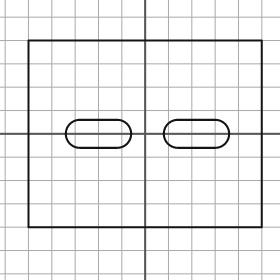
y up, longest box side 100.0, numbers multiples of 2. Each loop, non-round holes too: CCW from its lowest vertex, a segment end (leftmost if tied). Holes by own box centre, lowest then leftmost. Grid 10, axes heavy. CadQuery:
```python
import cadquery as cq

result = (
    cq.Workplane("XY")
    .moveTo(-50.0, -40.0)
    .lineTo(50.0, -40.0)
    .lineTo(50.0, 40.0)
    .lineTo(-50.0, 40.0)
    .close()
    .moveTo(-28.0, -6.0)
    .lineTo(-12.0, -6.0)
    .threePointArc((-6.0, 0.0), (-12.0, 6.0))
    .lineTo(-28.0, 6.0)
    .threePointArc((-34.0, 0.0), (-28.0, -6.0))
    .close()
    .moveTo(14.0, -6.0)
    .lineTo(30.0, -6.0)
    .threePointArc((36.0, 0.0), (30.0, 6.0))
    .lineTo(14.0, 6.0)
    .threePointArc((8.0, 0.0), (14.0, -6.0))
    .close()
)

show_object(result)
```